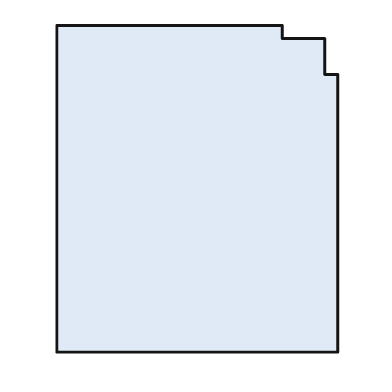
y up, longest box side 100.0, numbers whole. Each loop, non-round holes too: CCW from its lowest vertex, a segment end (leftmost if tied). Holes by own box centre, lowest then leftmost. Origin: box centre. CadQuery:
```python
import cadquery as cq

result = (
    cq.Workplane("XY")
    .moveTo(-43.0, -50.0)
    .lineTo(43.0, -50.0)
    .lineTo(43.0, 35.0)
    .lineTo(39.0, 35.0)
    .lineTo(39.0, 46.0)
    .lineTo(26.0, 46.0)
    .lineTo(26.0, 50.0)
    .lineTo(-43.0, 50.0)
    .close()
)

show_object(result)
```